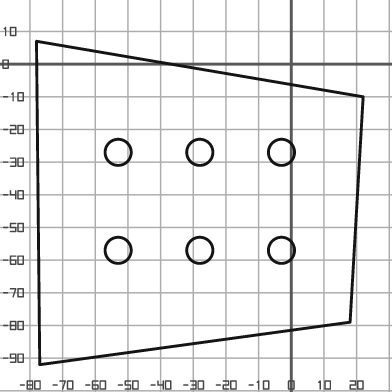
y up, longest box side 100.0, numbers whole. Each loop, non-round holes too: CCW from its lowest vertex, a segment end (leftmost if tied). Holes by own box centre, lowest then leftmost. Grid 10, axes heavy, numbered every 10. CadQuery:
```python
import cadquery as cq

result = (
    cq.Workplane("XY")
    .moveTo(-77.0, -92.0)
    .lineTo(18.0, -79.0)
    .lineTo(22.0, -10.0)
    .lineTo(-78.0, 7.0)
    .close()
    .moveTo(-53.0, -57.0)
    .circle(4.0)
    .moveTo(-28.0, -57.0)
    .circle(4.0)
    .moveTo(-3.0, -57.0)
    .circle(4.0)
    .moveTo(-53.0, -27.0)
    .circle(4.0)
    .moveTo(-28.0, -27.0)
    .circle(4.0)
    .moveTo(-3.0, -27.0)
    .circle(4.0)
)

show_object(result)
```